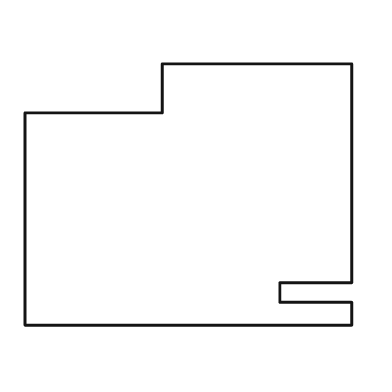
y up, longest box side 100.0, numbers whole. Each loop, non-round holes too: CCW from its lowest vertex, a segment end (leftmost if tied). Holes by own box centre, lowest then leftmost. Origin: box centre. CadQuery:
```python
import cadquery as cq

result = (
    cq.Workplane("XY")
    .moveTo(-50.0, -40.0)
    .lineTo(50.0, -40.0)
    .lineTo(50.0, -33.0)
    .lineTo(28.0, -33.0)
    .lineTo(28.0, -27.0)
    .lineTo(50.0, -27.0)
    .lineTo(50.0, 40.0)
    .lineTo(-8.0, 40.0)
    .lineTo(-8.0, 25.0)
    .lineTo(-50.0, 25.0)
    .close()
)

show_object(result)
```